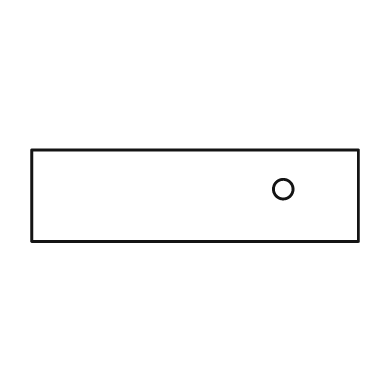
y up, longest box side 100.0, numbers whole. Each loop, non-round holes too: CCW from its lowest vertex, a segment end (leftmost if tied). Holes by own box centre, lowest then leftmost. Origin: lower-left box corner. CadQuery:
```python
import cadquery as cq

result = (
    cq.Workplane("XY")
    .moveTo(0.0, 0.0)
    .lineTo(100.0, 0.0)
    .lineTo(100.0, 28.0)
    .lineTo(0.0, 28.0)
    .close()
    .moveTo(77.0, 16.0)
    .circle(3.0)
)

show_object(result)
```